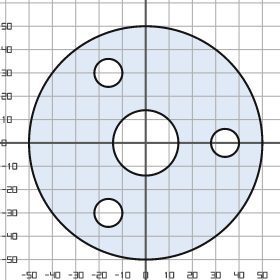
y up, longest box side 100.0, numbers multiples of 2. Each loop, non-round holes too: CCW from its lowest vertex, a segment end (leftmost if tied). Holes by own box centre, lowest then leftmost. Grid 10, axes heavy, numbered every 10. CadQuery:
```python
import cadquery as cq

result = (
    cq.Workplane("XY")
    .moveTo(0.0, 0.0)
    .circle(50.0)
    .moveTo(-16.0, -30.0)
    .circle(6.0)
    .moveTo(0.0, 0.0)
    .circle(14.0)
    .moveTo(34.0, 0.0)
    .circle(6.0)
    .moveTo(-16.0, 30.0)
    .circle(6.0)
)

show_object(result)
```